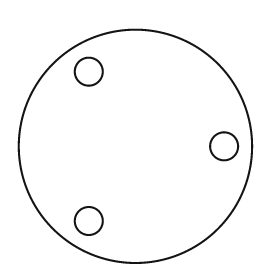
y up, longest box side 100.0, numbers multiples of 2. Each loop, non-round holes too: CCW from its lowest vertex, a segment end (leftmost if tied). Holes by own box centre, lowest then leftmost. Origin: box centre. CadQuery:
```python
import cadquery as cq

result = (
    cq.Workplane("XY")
    .moveTo(0.0, 0.0)
    .circle(50.0)
    .moveTo(-20.0, -32.0)
    .circle(6.0)
    .moveTo(38.0, 0.0)
    .circle(6.0)
    .moveTo(-20.0, 32.0)
    .circle(6.0)
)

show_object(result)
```